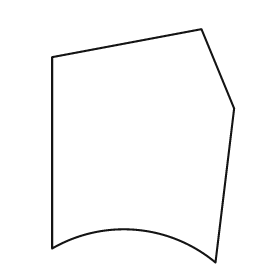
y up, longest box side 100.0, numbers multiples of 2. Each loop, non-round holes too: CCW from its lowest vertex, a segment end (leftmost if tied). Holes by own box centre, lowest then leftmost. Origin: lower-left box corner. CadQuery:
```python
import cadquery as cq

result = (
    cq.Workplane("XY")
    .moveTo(70.0, 0.0)
    .lineTo(78.0, 66.0)
    .lineTo(64.0, 100.0)
    .lineTo(0.0, 88.0)
    .lineTo(0.0, 6.0)
    .threePointArc((36.0, 14.0), (70.0, 0.0))
    .close()
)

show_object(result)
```